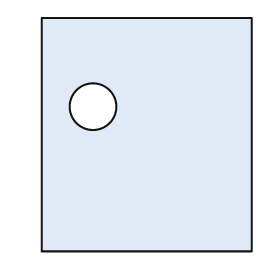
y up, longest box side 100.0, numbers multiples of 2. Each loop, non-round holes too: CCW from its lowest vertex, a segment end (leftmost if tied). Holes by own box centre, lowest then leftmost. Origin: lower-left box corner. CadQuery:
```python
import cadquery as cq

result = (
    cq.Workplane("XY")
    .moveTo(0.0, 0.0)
    .lineTo(90.0, 0.0)
    .lineTo(90.0, 100.0)
    .lineTo(0.0, 100.0)
    .close()
    .moveTo(22.0, 62.0)
    .circle(10.0)
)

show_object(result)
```